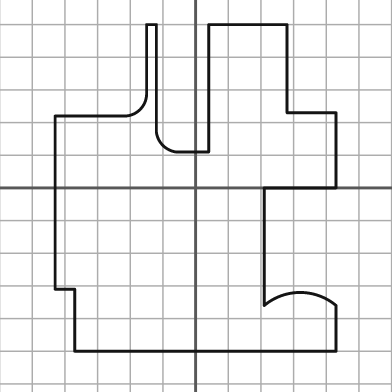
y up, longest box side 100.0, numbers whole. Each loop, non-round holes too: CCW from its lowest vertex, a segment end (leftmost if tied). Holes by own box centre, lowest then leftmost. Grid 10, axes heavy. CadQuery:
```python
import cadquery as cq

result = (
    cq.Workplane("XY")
    .moveTo(-37.0, -50.0)
    .lineTo(43.0, -50.0)
    .lineTo(43.0, -36.0)
    .threePointArc((32.0, -32.0), (21.0, -36.0))
    .lineTo(21.0, 0.0)
    .lineTo(43.0, 0.0)
    .lineTo(43.0, 23.0)
    .lineTo(28.0, 23.0)
    .lineTo(28.0, 50.0)
    .lineTo(4.0, 50.0)
    .lineTo(4.0, 11.0)
    .lineTo(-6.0, 11.0)
    .threePointArc((-10.0, 13.0), (-12.0, 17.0))
    .lineTo(-12.0, 50.0)
    .lineTo(-15.0, 50.0)
    .lineTo(-15.0, 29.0)
    .threePointArc((-17.0, 24.0), (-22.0, 22.0))
    .lineTo(-43.0, 22.0)
    .lineTo(-43.0, -31.0)
    .lineTo(-37.0, -31.0)
    .close()
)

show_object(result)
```